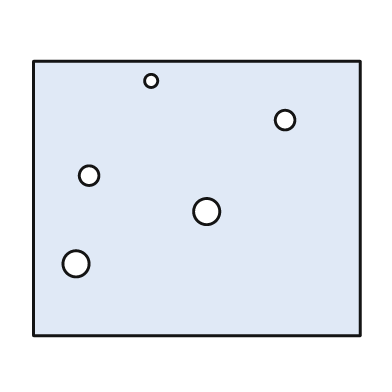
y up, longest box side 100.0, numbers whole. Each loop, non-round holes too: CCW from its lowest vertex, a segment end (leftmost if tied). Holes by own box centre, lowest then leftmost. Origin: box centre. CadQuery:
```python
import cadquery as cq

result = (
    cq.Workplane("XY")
    .moveTo(-50.0, -42.0)
    .lineTo(50.0, -42.0)
    .lineTo(50.0, 42.0)
    .lineTo(-50.0, 42.0)
    .close()
    .moveTo(-37.0, -20.0)
    .circle(4.0)
    .moveTo(3.0, -4.0)
    .circle(4.0)
    .moveTo(-33.0, 7.0)
    .circle(3.0)
    .moveTo(27.0, 24.0)
    .circle(3.0)
    .moveTo(-14.0, 36.0)
    .circle(2.0)
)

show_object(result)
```